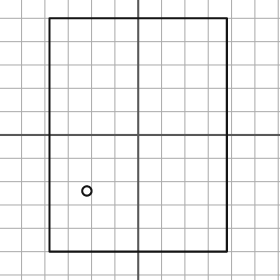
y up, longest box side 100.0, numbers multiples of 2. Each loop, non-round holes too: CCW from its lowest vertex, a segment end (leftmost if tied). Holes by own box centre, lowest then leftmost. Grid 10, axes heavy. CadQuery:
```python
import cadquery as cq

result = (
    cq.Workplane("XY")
    .moveTo(-38.0, -50.0)
    .lineTo(38.0, -50.0)
    .lineTo(38.0, 50.0)
    .lineTo(-38.0, 50.0)
    .close()
    .moveTo(-22.0, -24.0)
    .circle(2.0)
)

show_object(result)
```